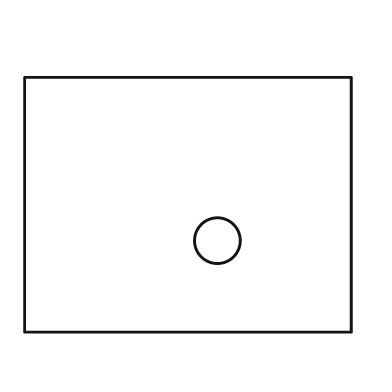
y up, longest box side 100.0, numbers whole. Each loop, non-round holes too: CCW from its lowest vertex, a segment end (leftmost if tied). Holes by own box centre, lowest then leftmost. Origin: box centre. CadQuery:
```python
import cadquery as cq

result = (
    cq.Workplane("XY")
    .moveTo(-50.0, -39.0)
    .lineTo(50.0, -39.0)
    .lineTo(50.0, 39.0)
    .lineTo(-50.0, 39.0)
    .close()
    .moveTo(9.0, -11.0)
    .circle(7.0)
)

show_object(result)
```